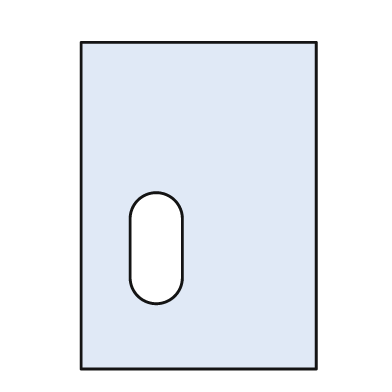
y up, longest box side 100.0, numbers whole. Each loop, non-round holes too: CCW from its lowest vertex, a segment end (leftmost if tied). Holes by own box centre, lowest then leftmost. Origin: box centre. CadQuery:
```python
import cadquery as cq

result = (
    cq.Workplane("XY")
    .moveTo(-36.0, -50.0)
    .lineTo(36.0, -50.0)
    .lineTo(36.0, 50.0)
    .lineTo(-36.0, 50.0)
    .close()
    .moveTo(-21.0, -22.0)
    .threePointArc((-13.0, -30.0), (-5.0, -22.0))
    .lineTo(-5.0, -4.0)
    .threePointArc((-13.0, 4.0), (-21.0, -4.0))
    .close()
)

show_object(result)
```